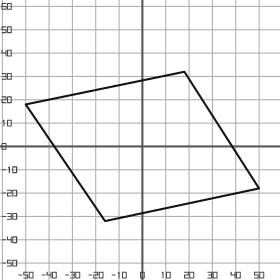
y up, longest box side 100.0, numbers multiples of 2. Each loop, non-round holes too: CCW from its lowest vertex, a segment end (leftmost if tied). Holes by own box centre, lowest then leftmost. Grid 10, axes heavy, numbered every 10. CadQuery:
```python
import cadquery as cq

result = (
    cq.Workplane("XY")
    .moveTo(-16.0, -32.0)
    .lineTo(50.0, -18.0)
    .lineTo(18.0, 32.0)
    .lineTo(-50.0, 18.0)
    .close()
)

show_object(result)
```